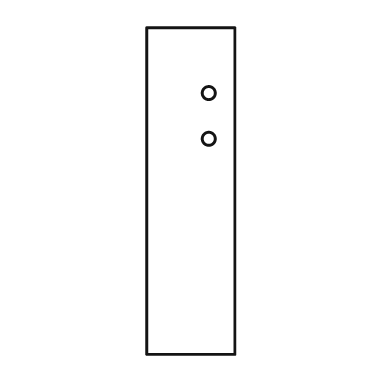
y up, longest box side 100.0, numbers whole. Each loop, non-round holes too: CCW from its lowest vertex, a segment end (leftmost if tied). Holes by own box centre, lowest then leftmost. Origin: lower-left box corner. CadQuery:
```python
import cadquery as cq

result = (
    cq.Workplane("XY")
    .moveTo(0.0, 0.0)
    .lineTo(27.0, 0.0)
    .lineTo(27.0, 100.0)
    .lineTo(0.0, 100.0)
    .close()
    .moveTo(19.0, 66.0)
    .circle(2.0)
    .moveTo(19.0, 80.0)
    .circle(2.0)
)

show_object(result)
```